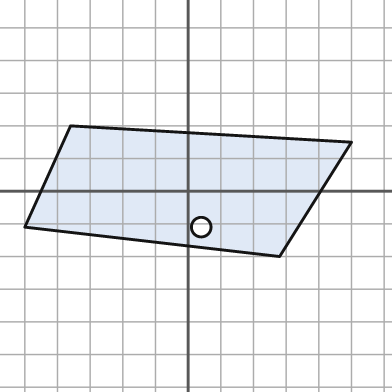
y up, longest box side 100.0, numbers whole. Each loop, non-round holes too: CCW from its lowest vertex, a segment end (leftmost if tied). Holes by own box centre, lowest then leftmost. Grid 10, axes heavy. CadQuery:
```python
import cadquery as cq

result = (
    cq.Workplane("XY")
    .moveTo(28.0, -20.0)
    .lineTo(50.0, 15.0)
    .lineTo(-36.0, 20.0)
    .lineTo(-50.0, -11.0)
    .close()
    .moveTo(4.0, -11.0)
    .circle(3.0)
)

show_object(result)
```